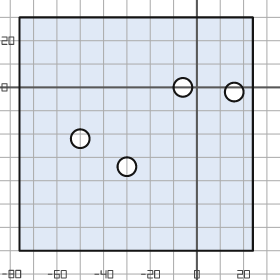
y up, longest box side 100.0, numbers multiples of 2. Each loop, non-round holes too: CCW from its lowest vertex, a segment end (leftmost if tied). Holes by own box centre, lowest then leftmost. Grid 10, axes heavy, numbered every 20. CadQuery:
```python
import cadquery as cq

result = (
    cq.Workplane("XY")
    .moveTo(-76.0, -70.0)
    .lineTo(24.0, -70.0)
    .lineTo(24.0, 30.0)
    .lineTo(-76.0, 30.0)
    .close()
    .moveTo(-30.0, -34.0)
    .circle(4.0)
    .moveTo(-50.0, -22.0)
    .circle(4.0)
    .moveTo(16.0, -2.0)
    .circle(4.0)
    .moveTo(-6.0, 0.0)
    .circle(4.0)
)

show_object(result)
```